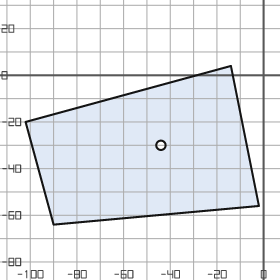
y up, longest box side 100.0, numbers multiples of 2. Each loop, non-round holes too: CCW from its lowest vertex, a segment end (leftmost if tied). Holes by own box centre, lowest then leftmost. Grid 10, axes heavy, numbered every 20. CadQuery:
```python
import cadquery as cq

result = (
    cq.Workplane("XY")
    .moveTo(-90.0, -64.0)
    .lineTo(-2.0, -56.0)
    .lineTo(-14.0, 4.0)
    .lineTo(-102.0, -20.0)
    .close()
    .moveTo(-44.0, -30.0)
    .circle(2.0)
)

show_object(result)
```